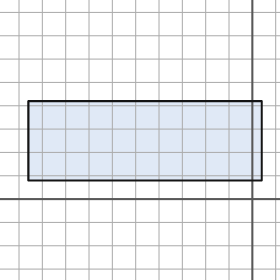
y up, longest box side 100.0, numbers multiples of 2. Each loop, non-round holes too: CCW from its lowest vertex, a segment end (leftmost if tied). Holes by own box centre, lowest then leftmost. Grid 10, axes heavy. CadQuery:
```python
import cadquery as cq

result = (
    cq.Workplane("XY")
    .moveTo(-96.0, 8.0)
    .lineTo(4.0, 8.0)
    .lineTo(4.0, 42.0)
    .lineTo(-96.0, 42.0)
    .close()
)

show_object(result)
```